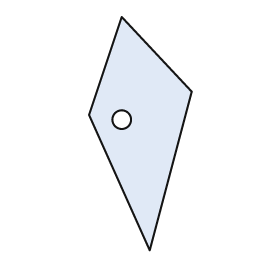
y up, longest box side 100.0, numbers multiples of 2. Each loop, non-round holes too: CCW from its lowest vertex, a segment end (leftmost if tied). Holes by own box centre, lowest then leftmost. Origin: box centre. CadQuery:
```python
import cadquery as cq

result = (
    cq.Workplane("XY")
    .moveTo(4.0, -50.0)
    .lineTo(22.0, 18.0)
    .lineTo(-8.0, 50.0)
    .lineTo(-22.0, 8.0)
    .close()
    .moveTo(-8.0, 6.0)
    .circle(4.0)
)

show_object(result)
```